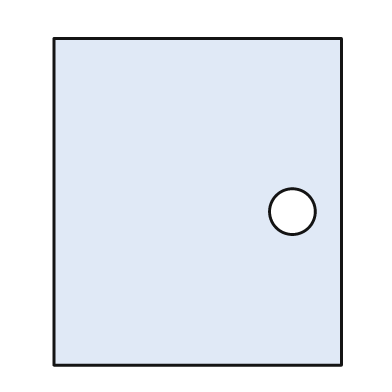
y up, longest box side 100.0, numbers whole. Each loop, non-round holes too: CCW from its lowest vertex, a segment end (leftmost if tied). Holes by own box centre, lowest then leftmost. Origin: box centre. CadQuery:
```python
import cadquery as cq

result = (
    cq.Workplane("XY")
    .moveTo(-44.0, -50.0)
    .lineTo(44.0, -50.0)
    .lineTo(44.0, 50.0)
    .lineTo(-44.0, 50.0)
    .close()
    .moveTo(29.0, -3.0)
    .circle(7.0)
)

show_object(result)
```